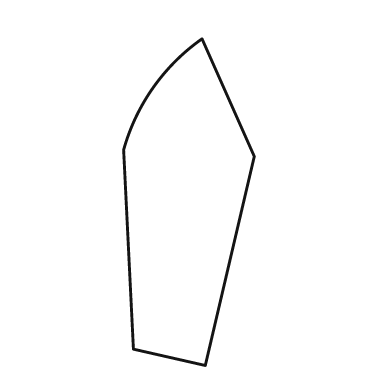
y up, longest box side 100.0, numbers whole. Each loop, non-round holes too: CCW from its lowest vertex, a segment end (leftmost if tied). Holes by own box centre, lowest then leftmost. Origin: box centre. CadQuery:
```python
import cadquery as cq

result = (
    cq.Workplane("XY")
    .moveTo(5.0, -50.0)
    .lineTo(20.0, 14.0)
    .lineTo(4.0, 50.0)
    .threePointArc((-11.0, 35.0), (-20.0, 16.0))
    .lineTo(-17.0, -45.0)
    .close()
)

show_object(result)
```